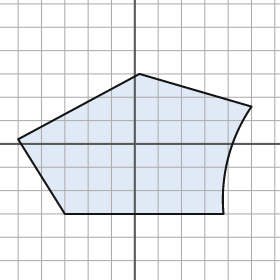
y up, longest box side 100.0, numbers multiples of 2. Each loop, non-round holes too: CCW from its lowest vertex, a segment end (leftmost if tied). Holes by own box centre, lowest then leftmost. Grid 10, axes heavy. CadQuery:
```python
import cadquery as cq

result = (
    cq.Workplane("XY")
    .moveTo(-30.0, -30.0)
    .lineTo(38.0, -30.0)
    .threePointArc((40.0, -6.0), (50.0, 16.0))
    .lineTo(2.0, 30.0)
    .lineTo(-50.0, 2.0)
    .close()
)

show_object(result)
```